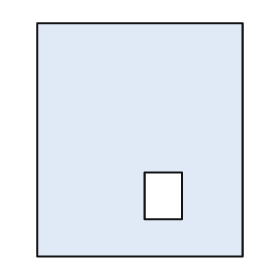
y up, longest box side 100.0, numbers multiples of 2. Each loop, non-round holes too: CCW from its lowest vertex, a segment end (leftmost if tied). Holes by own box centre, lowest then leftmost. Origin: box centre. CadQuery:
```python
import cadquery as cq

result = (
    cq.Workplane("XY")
    .moveTo(-44.0, -50.0)
    .lineTo(44.0, -50.0)
    .lineTo(44.0, 50.0)
    .lineTo(-44.0, 50.0)
    .close()
    .moveTo(2.0, -34.0)
    .lineTo(18.0, -34.0)
    .lineTo(18.0, -14.0)
    .lineTo(2.0, -14.0)
    .close()
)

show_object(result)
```